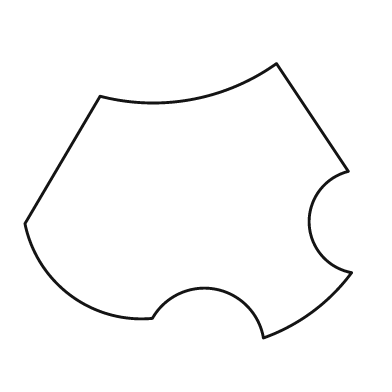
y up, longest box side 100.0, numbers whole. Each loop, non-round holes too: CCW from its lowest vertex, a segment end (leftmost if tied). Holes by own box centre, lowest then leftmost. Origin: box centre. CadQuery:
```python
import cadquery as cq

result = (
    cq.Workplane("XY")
    .moveTo(23.0, -42.0)
    .threePointArc((38.0, -34.0), (50.0, -22.0))
    .threePointArc((37.0, -7.0), (49.0, 9.0))
    .lineTo(27.0, 42.0)
    .threePointArc((1.0, 31.0), (-27.0, 32.0))
    .lineTo(-50.0, -7.0)
    .threePointArc((-36.0, -29.0), (-11.0, -36.0))
    .threePointArc((8.0, -27.0), (23.0, -42.0))
    .close()
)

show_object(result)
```